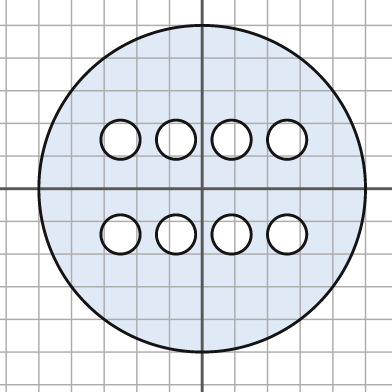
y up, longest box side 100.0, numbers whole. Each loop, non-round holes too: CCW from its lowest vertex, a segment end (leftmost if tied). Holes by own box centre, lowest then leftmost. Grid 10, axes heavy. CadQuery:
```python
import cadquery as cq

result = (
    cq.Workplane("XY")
    .moveTo(0.0, 0.0)
    .circle(50.0)
    .moveTo(-25.0, -14.0)
    .circle(6.0)
    .moveTo(-8.0, -14.0)
    .circle(6.0)
    .moveTo(9.0, -14.0)
    .circle(6.0)
    .moveTo(26.0, -14.0)
    .circle(6.0)
    .moveTo(-25.0, 15.0)
    .circle(6.0)
    .moveTo(-8.0, 15.0)
    .circle(6.0)
    .moveTo(9.0, 15.0)
    .circle(6.0)
    .moveTo(26.0, 15.0)
    .circle(6.0)
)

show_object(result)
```